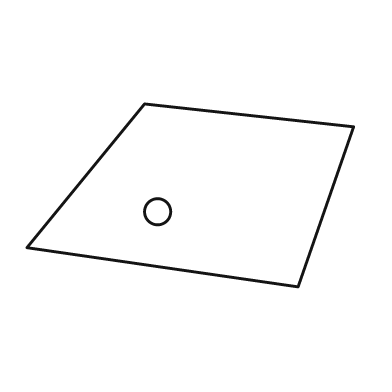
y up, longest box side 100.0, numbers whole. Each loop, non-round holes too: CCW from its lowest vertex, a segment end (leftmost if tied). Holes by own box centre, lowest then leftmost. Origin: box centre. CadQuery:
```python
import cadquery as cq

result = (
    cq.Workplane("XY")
    .moveTo(33.0, -28.0)
    .lineTo(50.0, 21.0)
    .lineTo(-14.0, 28.0)
    .lineTo(-50.0, -16.0)
    .close()
    .moveTo(-10.0, -5.0)
    .circle(4.0)
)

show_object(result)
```